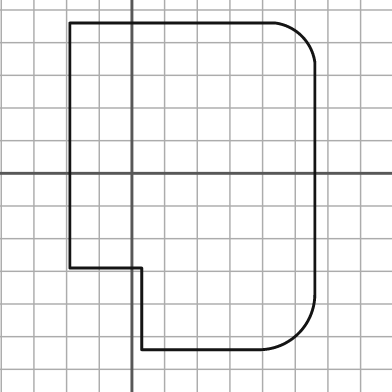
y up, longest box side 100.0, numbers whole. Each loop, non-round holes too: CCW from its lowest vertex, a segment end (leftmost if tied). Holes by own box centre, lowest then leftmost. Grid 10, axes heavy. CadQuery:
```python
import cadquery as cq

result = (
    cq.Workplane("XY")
    .moveTo(3.0, -54.0)
    .lineTo(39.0, -54.0)
    .threePointArc((51.0, -49.0), (56.0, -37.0))
    .lineTo(56.0, 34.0)
    .threePointArc((52.0, 42.0), (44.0, 46.0))
    .lineTo(-19.0, 46.0)
    .lineTo(-19.0, -29.0)
    .lineTo(3.0, -29.0)
    .close()
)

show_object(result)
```